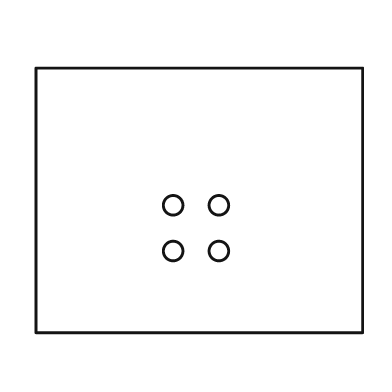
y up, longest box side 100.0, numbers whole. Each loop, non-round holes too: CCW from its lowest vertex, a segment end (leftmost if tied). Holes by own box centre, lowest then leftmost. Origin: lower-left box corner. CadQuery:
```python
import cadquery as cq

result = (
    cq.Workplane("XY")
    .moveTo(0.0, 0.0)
    .lineTo(100.0, 0.0)
    .lineTo(100.0, 81.0)
    .lineTo(0.0, 81.0)
    .close()
    .moveTo(42.0, 25.0)
    .circle(3.0)
    .moveTo(56.0, 25.0)
    .circle(3.0)
    .moveTo(42.0, 39.0)
    .circle(3.0)
    .moveTo(56.0, 39.0)
    .circle(3.0)
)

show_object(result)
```